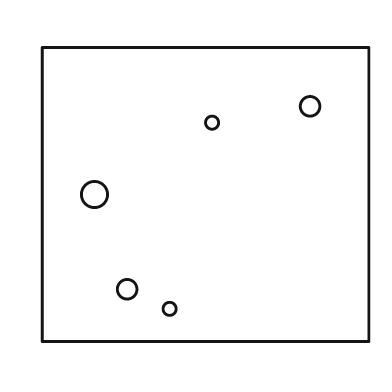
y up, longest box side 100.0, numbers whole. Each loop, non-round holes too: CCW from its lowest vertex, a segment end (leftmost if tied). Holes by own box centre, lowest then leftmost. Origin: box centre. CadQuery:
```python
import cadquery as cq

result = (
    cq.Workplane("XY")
    .moveTo(-50.0, -45.0)
    .lineTo(50.0, -45.0)
    .lineTo(50.0, 45.0)
    .lineTo(-50.0, 45.0)
    .close()
    .moveTo(-11.0, -35.0)
    .circle(2.0)
    .moveTo(-24.0, -29.0)
    .circle(3.0)
    .moveTo(-34.0, 0.0)
    .circle(4.0)
    .moveTo(2.0, 22.0)
    .circle(2.0)
    .moveTo(32.0, 27.0)
    .circle(3.0)
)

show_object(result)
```